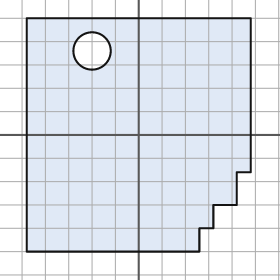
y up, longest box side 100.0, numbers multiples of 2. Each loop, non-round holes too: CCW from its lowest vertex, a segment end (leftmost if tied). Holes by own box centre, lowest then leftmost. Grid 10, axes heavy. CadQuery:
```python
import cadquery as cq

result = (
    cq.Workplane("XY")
    .moveTo(-48.0, -50.0)
    .lineTo(26.0, -50.0)
    .lineTo(26.0, -40.0)
    .lineTo(32.0, -40.0)
    .lineTo(32.0, -30.0)
    .lineTo(42.0, -30.0)
    .lineTo(42.0, -16.0)
    .lineTo(48.0, -16.0)
    .lineTo(48.0, 50.0)
    .lineTo(-48.0, 50.0)
    .close()
    .moveTo(-20.0, 36.0)
    .circle(8.0)
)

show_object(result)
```